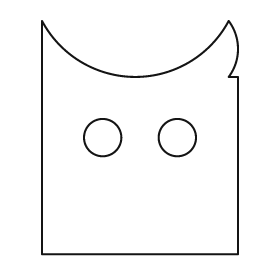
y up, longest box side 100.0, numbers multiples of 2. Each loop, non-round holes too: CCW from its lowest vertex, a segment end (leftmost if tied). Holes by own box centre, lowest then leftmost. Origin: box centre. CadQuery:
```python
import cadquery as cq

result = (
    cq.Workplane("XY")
    .moveTo(-42.0, -50.0)
    .lineTo(42.0, -50.0)
    .lineTo(42.0, 26.0)
    .lineTo(38.0, 26.0)
    .threePointArc((42.0, 38.0), (38.0, 50.0))
    .threePointArc((-2.0, 26.0), (-42.0, 50.0))
    .close()
    .moveTo(-16.0, 0.0)
    .circle(8.0)
    .moveTo(16.0, 0.0)
    .circle(8.0)
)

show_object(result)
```